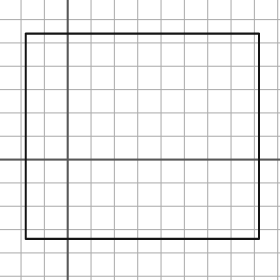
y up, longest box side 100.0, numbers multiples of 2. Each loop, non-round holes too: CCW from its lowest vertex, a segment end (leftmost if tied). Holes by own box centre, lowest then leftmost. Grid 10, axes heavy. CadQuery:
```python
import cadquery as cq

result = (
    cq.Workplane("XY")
    .moveTo(-18.0, -34.0)
    .lineTo(82.0, -34.0)
    .lineTo(82.0, 54.0)
    .lineTo(-18.0, 54.0)
    .close()
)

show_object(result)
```